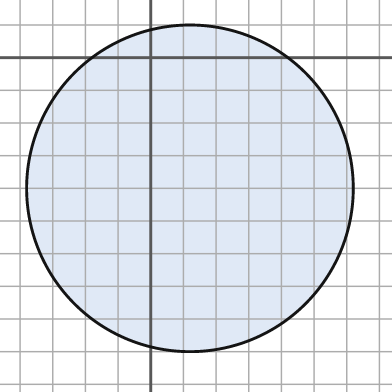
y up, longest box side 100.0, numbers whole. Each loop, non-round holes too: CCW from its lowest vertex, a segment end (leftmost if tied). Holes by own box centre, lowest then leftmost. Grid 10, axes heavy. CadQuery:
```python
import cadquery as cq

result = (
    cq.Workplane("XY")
    .moveTo(12.0, -40.0)
    .circle(50.0)
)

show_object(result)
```